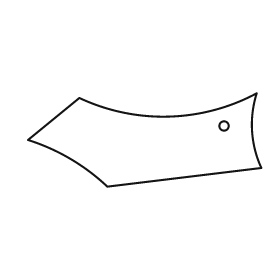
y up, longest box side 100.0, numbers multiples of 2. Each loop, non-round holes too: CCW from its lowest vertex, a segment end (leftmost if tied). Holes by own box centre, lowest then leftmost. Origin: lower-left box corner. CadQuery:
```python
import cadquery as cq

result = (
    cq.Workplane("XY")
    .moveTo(34.0, 0.0)
    .lineTo(100.0, 8.0)
    .threePointArc((96.0, 24.0), (98.0, 40.0))
    .threePointArc((60.0, 30.0), (22.0, 38.0))
    .lineTo(0.0, 20.0)
    .threePointArc((18.0, 12.0), (34.0, 0.0))
    .close()
    .moveTo(84.0, 26.0)
    .circle(2.0)
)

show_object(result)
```